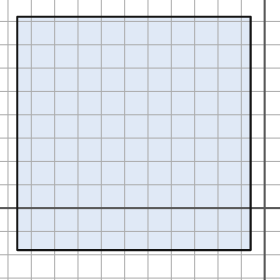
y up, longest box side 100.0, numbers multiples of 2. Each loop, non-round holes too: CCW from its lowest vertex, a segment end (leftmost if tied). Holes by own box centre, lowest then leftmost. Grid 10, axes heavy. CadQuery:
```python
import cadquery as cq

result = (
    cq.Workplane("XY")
    .moveTo(-106.0, -18.0)
    .lineTo(-6.0, -18.0)
    .lineTo(-6.0, 82.0)
    .lineTo(-106.0, 82.0)
    .close()
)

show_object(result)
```